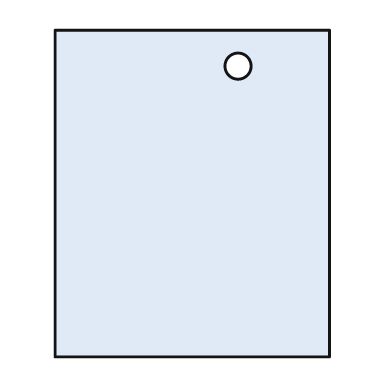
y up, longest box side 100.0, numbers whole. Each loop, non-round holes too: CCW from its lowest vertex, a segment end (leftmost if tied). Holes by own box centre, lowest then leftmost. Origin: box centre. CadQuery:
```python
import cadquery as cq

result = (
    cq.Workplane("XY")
    .moveTo(-42.0, -50.0)
    .lineTo(42.0, -50.0)
    .lineTo(42.0, 50.0)
    .lineTo(-42.0, 50.0)
    .close()
    .moveTo(14.0, 39.0)
    .circle(4.0)
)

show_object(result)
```